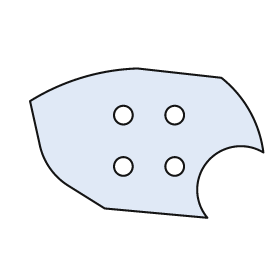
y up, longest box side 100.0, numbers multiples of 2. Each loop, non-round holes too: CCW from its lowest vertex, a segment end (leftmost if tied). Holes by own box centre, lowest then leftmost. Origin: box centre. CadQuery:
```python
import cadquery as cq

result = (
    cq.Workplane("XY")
    .moveTo(26.0, -32.0)
    .threePointArc((26.0, -8.0), (50.0, -4.0))
    .threePointArc((44.0, 14.0), (32.0, 28.0))
    .lineTo(-4.0, 32.0)
    .threePointArc((-28.0, 28.0), (-50.0, 18.0))
    .lineTo(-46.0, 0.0)
    .threePointArc((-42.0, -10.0), (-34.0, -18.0))
    .lineTo(-18.0, -28.0)
    .close()
    .moveTo(-10.0, -10.0)
    .circle(4.0)
    .moveTo(12.0, -10.0)
    .circle(4.0)
    .moveTo(-10.0, 12.0)
    .circle(4.0)
    .moveTo(12.0, 12.0)
    .circle(4.0)
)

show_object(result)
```